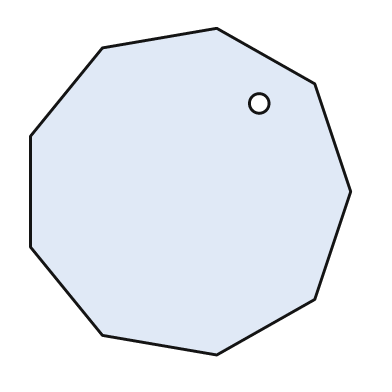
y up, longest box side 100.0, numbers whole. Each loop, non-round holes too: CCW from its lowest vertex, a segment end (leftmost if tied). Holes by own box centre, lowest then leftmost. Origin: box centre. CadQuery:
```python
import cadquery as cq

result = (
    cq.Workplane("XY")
    .moveTo(8.0, -50.0)
    .lineTo(38.0, -33.0)
    .lineTo(49.0, 0.0)
    .lineTo(38.0, 33.0)
    .lineTo(8.0, 50.0)
    .lineTo(-27.0, 44.0)
    .lineTo(-49.0, 17.0)
    .lineTo(-49.0, -17.0)
    .lineTo(-27.0, -44.0)
    .close()
    .moveTo(21.0, 27.0)
    .circle(3.0)
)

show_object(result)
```